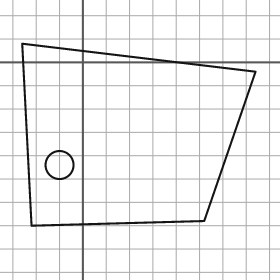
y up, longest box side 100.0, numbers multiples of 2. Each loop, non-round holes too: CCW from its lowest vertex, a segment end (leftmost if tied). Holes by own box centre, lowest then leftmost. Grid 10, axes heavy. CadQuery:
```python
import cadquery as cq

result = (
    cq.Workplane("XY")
    .moveTo(-22.0, -70.0)
    .lineTo(52.0, -68.0)
    .lineTo(74.0, -4.0)
    .lineTo(-26.0, 8.0)
    .close()
    .moveTo(-10.0, -44.0)
    .circle(6.0)
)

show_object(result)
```